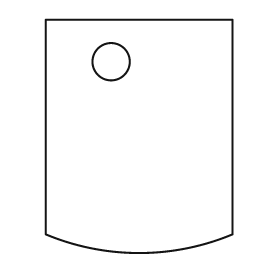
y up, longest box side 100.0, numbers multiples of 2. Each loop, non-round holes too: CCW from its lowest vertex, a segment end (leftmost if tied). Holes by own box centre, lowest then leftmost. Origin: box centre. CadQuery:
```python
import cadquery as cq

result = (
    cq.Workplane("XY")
    .moveTo(-40.0, -42.0)
    .threePointArc((0.0, -50.0), (40.0, -42.0))
    .lineTo(40.0, 50.0)
    .lineTo(-40.0, 50.0)
    .close()
    .moveTo(-12.0, 32.0)
    .circle(8.0)
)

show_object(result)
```